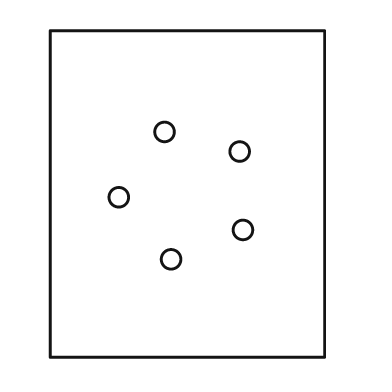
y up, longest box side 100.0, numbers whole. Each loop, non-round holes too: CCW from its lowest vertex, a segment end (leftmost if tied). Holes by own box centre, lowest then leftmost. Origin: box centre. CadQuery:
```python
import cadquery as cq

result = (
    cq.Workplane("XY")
    .moveTo(-42.0, -50.0)
    .lineTo(42.0, -50.0)
    .lineTo(42.0, 50.0)
    .lineTo(-42.0, 50.0)
    .close()
    .moveTo(-5.0, -20.0)
    .circle(3.0)
    .moveTo(17.0, -11.0)
    .circle(3.0)
    .moveTo(-21.0, -1.0)
    .circle(3.0)
    .moveTo(16.0, 13.0)
    .circle(3.0)
    .moveTo(-7.0, 19.0)
    .circle(3.0)
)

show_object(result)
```